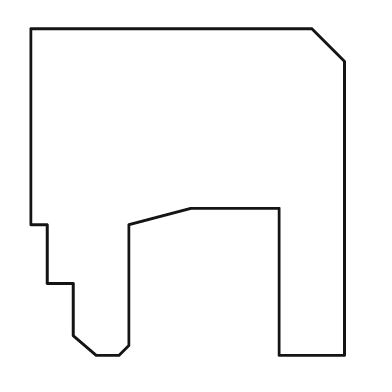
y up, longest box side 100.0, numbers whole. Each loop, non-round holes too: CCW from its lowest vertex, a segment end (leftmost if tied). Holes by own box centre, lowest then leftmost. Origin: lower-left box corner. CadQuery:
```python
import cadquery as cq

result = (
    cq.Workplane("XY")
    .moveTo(20.0, 0.0)
    .lineTo(27.0, 0.0)
    .lineTo(30.0, 3.0)
    .lineTo(30.0, 40.0)
    .lineTo(49.0, 45.0)
    .lineTo(76.0, 45.0)
    .lineTo(76.0, 0.0)
    .lineTo(96.0, 0.0)
    .lineTo(96.0, 90.0)
    .lineTo(86.0, 100.0)
    .lineTo(0.0, 100.0)
    .lineTo(0.0, 40.0)
    .lineTo(5.0, 40.0)
    .lineTo(5.0, 22.0)
    .lineTo(13.0, 22.0)
    .lineTo(13.0, 6.0)
    .close()
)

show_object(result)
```